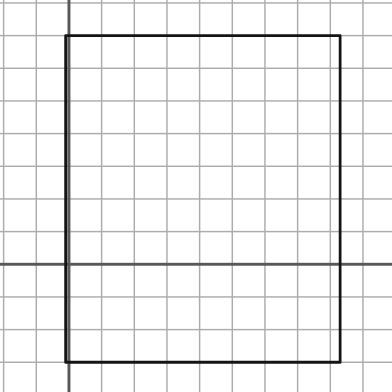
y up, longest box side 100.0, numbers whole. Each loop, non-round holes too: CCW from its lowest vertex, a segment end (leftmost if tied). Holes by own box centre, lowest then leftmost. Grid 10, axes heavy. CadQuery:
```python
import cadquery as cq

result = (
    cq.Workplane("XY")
    .moveTo(-1.0, -30.0)
    .lineTo(83.0, -30.0)
    .lineTo(83.0, 70.0)
    .lineTo(-1.0, 70.0)
    .close()
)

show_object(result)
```